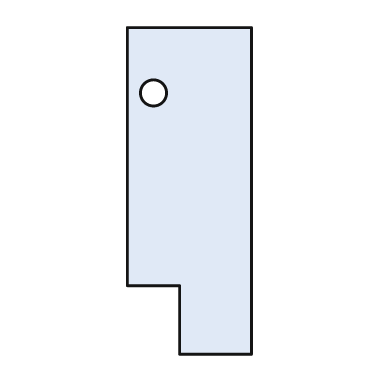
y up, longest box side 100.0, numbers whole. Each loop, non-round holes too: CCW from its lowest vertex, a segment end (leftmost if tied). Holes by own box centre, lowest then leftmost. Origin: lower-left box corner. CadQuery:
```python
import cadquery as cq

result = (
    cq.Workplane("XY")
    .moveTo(16.0, 0.0)
    .lineTo(38.0, 0.0)
    .lineTo(38.0, 100.0)
    .lineTo(0.0, 100.0)
    .lineTo(0.0, 21.0)
    .lineTo(16.0, 21.0)
    .close()
    .moveTo(8.0, 80.0)
    .circle(4.0)
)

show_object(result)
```